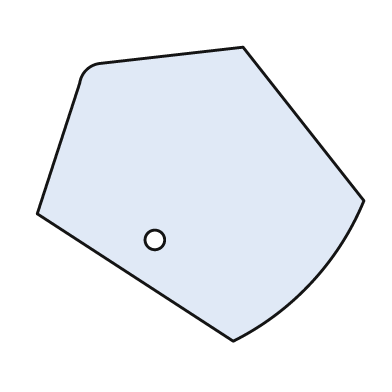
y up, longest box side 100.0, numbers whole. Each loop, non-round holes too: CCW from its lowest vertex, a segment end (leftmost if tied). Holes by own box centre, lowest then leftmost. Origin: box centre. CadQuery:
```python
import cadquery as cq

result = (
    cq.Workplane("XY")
    .moveTo(10.0, -45.0)
    .threePointArc((34.0, -27.0), (50.0, -2.0))
    .lineTo(13.0, 45.0)
    .lineTo(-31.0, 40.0)
    .threePointArc((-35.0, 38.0), (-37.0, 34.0))
    .lineTo(-50.0, -6.0)
    .close()
    .moveTo(-14.0, -14.0)
    .circle(3.0)
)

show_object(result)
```